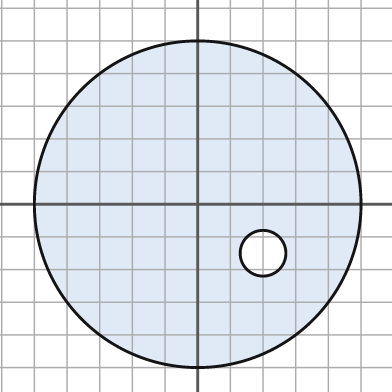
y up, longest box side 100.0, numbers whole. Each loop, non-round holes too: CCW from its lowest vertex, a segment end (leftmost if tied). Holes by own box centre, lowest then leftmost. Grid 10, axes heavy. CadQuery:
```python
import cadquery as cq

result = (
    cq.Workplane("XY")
    .moveTo(0.0, 0.0)
    .circle(50.0)
    .moveTo(20.0, -15.0)
    .circle(7.0)
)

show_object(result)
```